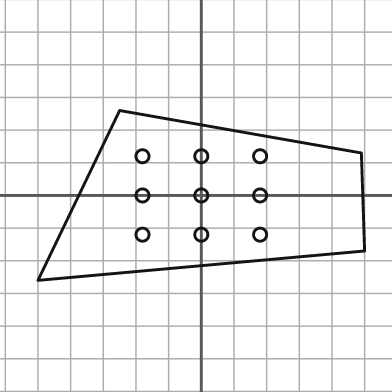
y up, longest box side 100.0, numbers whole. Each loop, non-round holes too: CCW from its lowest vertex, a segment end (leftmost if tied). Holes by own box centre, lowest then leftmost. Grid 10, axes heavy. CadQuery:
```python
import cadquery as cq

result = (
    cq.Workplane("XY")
    .moveTo(-50.0, -26.0)
    .lineTo(50.0, -17.0)
    .lineTo(49.0, 13.0)
    .lineTo(-25.0, 26.0)
    .close()
    .moveTo(-18.0, -12.0)
    .circle(2.0)
    .moveTo(0.0, -12.0)
    .circle(2.0)
    .moveTo(18.0, -12.0)
    .circle(2.0)
    .moveTo(-18.0, 0.0)
    .circle(2.0)
    .moveTo(0.0, 0.0)
    .circle(2.0)
    .moveTo(18.0, 0.0)
    .circle(2.0)
    .moveTo(-18.0, 12.0)
    .circle(2.0)
    .moveTo(0.0, 12.0)
    .circle(2.0)
    .moveTo(18.0, 12.0)
    .circle(2.0)
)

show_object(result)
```